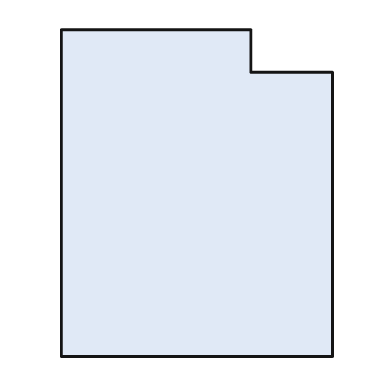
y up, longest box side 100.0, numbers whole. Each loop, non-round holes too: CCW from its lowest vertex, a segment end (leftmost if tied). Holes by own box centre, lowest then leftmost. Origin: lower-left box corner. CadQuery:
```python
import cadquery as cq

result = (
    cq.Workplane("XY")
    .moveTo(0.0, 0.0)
    .lineTo(83.0, 0.0)
    .lineTo(83.0, 87.0)
    .lineTo(58.0, 87.0)
    .lineTo(58.0, 100.0)
    .lineTo(0.0, 100.0)
    .close()
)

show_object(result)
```